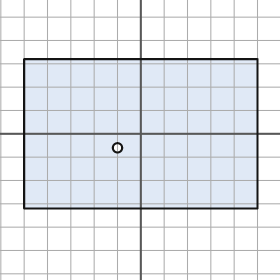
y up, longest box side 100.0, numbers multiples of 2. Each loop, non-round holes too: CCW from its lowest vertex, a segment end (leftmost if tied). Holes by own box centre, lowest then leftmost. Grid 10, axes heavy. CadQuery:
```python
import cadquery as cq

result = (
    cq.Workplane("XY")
    .moveTo(-50.0, -32.0)
    .lineTo(50.0, -32.0)
    .lineTo(50.0, 32.0)
    .lineTo(-50.0, 32.0)
    .close()
    .moveTo(-10.0, -6.0)
    .circle(2.0)
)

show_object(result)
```